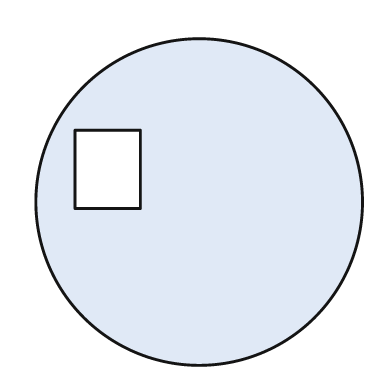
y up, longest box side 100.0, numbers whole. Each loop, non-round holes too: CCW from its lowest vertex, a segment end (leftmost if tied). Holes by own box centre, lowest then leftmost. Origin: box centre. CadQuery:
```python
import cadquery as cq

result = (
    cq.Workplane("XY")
    .moveTo(0.0, 0.0)
    .circle(50.0)
    .moveTo(-38.0, -2.0)
    .lineTo(-18.0, -2.0)
    .lineTo(-18.0, 22.0)
    .lineTo(-38.0, 22.0)
    .close()
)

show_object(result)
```